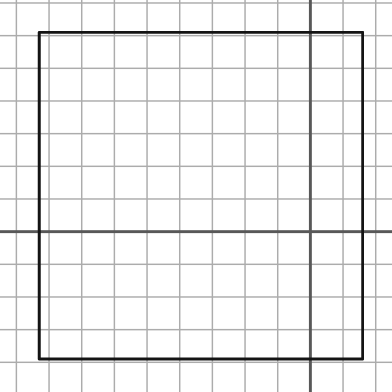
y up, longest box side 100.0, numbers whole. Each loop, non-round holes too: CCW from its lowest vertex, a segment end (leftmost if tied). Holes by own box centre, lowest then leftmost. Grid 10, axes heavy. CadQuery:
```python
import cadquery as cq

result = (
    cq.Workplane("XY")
    .moveTo(-83.0, -39.0)
    .lineTo(16.0, -39.0)
    .lineTo(16.0, 61.0)
    .lineTo(-83.0, 61.0)
    .close()
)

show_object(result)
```